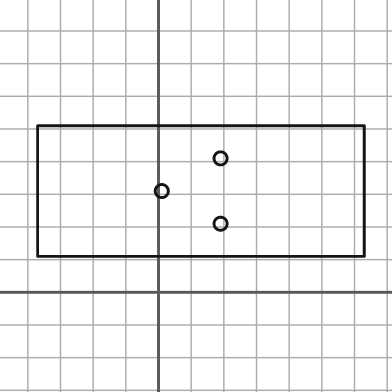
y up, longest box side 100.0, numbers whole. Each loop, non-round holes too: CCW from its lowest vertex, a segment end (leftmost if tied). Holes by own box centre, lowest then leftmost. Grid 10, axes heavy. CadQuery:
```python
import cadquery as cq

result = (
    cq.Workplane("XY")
    .moveTo(-37.0, 11.0)
    .lineTo(63.0, 11.0)
    .lineTo(63.0, 51.0)
    .lineTo(-37.0, 51.0)
    .close()
    .moveTo(19.0, 21.0)
    .circle(2.0)
    .moveTo(1.0, 31.0)
    .circle(2.0)
    .moveTo(19.0, 41.0)
    .circle(2.0)
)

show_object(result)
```